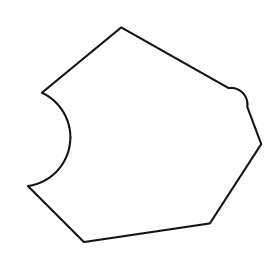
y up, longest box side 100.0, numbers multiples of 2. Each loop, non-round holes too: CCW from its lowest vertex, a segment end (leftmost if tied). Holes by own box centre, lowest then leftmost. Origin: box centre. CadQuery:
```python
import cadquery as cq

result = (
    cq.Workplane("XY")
    .moveTo(-26.0, -46.0)
    .lineTo(28.0, -38.0)
    .lineTo(50.0, -4.0)
    .lineTo(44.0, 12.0)
    .threePointArc((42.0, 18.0), (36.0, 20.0))
    .lineTo(-10.0, 46.0)
    .lineTo(-44.0, 18.0)
    .threePointArc((-32.0, -4.0), (-50.0, -22.0))
    .close()
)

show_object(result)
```